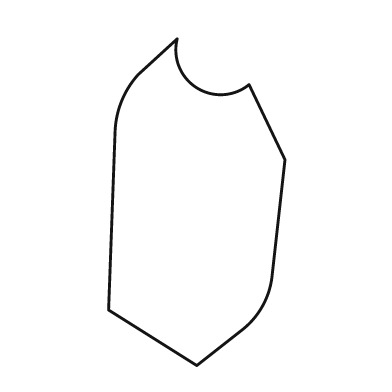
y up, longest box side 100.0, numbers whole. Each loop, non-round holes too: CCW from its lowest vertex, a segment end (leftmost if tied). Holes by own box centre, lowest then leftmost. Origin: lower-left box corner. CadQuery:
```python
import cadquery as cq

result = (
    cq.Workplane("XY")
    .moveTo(27.0, 0.0)
    .lineTo(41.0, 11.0)
    .threePointArc((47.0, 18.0), (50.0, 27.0))
    .lineTo(54.0, 63.0)
    .lineTo(43.0, 86.0)
    .threePointArc((27.0, 85.0), (21.0, 100.0))
    .lineTo(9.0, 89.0)
    .threePointArc((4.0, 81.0), (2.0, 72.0))
    .lineTo(0.0, 17.0)
    .close()
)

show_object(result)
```